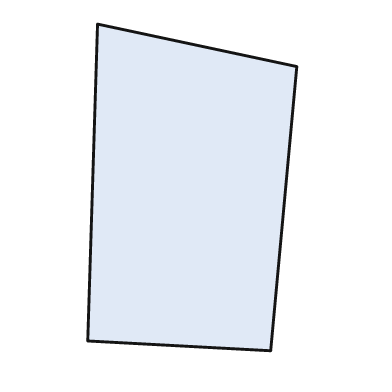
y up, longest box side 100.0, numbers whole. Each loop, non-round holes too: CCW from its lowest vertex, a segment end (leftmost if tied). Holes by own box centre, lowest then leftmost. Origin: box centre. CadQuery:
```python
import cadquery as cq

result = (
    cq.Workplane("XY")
    .moveTo(24.0, -50.0)
    .lineTo(32.0, 37.0)
    .lineTo(-29.0, 50.0)
    .lineTo(-32.0, -47.0)
    .close()
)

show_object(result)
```